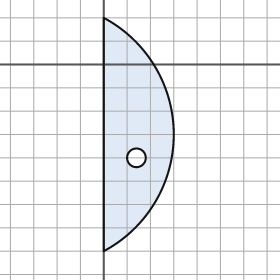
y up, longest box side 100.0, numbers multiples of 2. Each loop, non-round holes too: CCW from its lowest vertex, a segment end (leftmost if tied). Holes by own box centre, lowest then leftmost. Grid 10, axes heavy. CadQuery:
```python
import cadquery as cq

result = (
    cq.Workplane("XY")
    .moveTo(0.0, -80.0)
    .threePointArc((30.0, -30.0), (0.0, 20.0))
    .close()
    .moveTo(14.0, -40.0)
    .circle(4.0)
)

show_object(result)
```